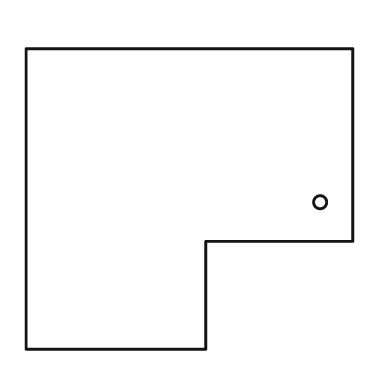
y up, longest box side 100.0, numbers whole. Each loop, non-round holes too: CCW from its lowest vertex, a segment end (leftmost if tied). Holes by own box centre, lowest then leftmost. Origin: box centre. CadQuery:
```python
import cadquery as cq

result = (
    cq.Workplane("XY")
    .moveTo(-50.0, -46.0)
    .lineTo(5.0, -46.0)
    .lineTo(5.0, -13.0)
    .lineTo(50.0, -13.0)
    .lineTo(50.0, 46.0)
    .lineTo(-50.0, 46.0)
    .close()
    .moveTo(40.0, -1.0)
    .circle(2.0)
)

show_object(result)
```